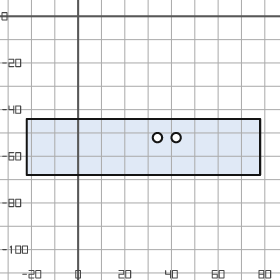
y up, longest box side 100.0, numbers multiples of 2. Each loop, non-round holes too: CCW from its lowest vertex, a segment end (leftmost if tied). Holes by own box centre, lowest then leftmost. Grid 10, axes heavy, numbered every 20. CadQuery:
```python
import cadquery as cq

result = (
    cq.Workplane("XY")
    .moveTo(-22.0, -68.0)
    .lineTo(78.0, -68.0)
    .lineTo(78.0, -44.0)
    .lineTo(-22.0, -44.0)
    .close()
    .moveTo(34.0, -52.0)
    .circle(2.0)
    .moveTo(42.0, -52.0)
    .circle(2.0)
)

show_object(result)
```